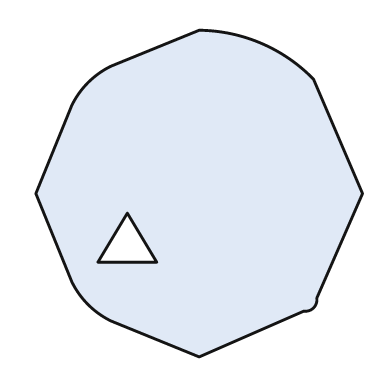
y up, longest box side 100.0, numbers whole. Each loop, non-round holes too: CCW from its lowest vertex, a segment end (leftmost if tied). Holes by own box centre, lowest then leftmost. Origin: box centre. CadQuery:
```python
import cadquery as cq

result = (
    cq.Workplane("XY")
    .moveTo(0.0, -50.0)
    .lineTo(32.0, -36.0)
    .threePointArc((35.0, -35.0), (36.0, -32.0))
    .lineTo(50.0, 0.0)
    .lineTo(35.0, 35.0)
    .threePointArc((19.0, 46.0), (0.0, 50.0))
    .lineTo(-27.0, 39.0)
    .threePointArc((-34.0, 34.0), (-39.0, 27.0))
    .lineTo(-50.0, 0.0)
    .lineTo(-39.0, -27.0)
    .threePointArc((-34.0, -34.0), (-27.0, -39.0))
    .close()
    .moveTo(-31.0, -21.0)
    .lineTo(-13.0, -21.0)
    .lineTo(-22.0, -6.0)
    .close()
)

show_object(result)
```